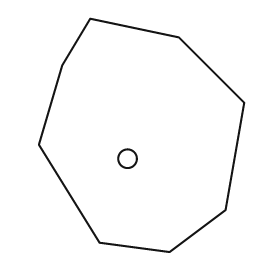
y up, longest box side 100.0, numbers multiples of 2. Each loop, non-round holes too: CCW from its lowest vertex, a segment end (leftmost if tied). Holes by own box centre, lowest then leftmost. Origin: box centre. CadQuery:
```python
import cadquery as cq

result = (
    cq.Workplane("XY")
    .moveTo(12.0, -50.0)
    .lineTo(36.0, -32.0)
    .lineTo(44.0, 14.0)
    .lineTo(16.0, 42.0)
    .lineTo(-22.0, 50.0)
    .lineTo(-34.0, 30.0)
    .lineTo(-44.0, -4.0)
    .lineTo(-18.0, -46.0)
    .close()
    .moveTo(-6.0, -10.0)
    .circle(4.0)
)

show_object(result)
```